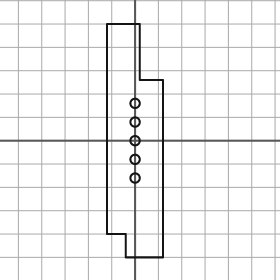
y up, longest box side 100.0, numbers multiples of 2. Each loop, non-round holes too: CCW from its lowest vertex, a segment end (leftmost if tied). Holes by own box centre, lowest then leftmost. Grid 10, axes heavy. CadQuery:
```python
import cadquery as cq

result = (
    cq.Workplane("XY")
    .moveTo(-4.0, -50.0)
    .lineTo(12.0, -50.0)
    .lineTo(12.0, 26.0)
    .lineTo(2.0, 26.0)
    .lineTo(2.0, 50.0)
    .lineTo(-12.0, 50.0)
    .lineTo(-12.0, -40.0)
    .lineTo(-4.0, -40.0)
    .close()
    .moveTo(0.0, -16.0)
    .circle(2.0)
    .moveTo(0.0, -8.0)
    .circle(2.0)
    .moveTo(0.0, 0.0)
    .circle(2.0)
    .moveTo(0.0, 8.0)
    .circle(2.0)
    .moveTo(0.0, 16.0)
    .circle(2.0)
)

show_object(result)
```